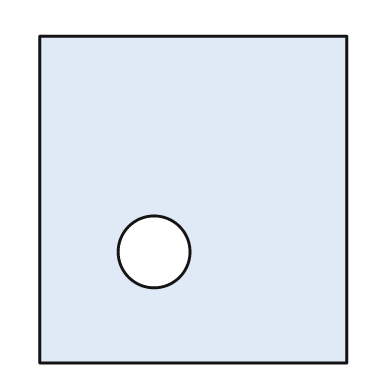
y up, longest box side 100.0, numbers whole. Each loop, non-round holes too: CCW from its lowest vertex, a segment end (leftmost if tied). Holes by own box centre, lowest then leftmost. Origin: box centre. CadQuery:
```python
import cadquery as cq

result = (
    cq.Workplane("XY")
    .moveTo(-47.0, -50.0)
    .lineTo(47.0, -50.0)
    .lineTo(47.0, 50.0)
    .lineTo(-47.0, 50.0)
    .close()
    .moveTo(-12.0, -16.0)
    .circle(11.0)
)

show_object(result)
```